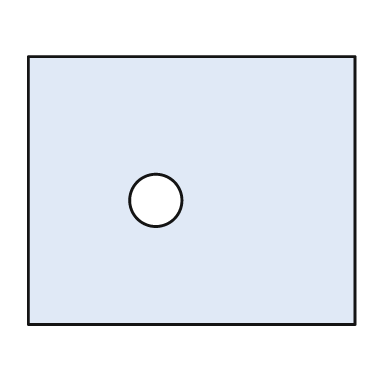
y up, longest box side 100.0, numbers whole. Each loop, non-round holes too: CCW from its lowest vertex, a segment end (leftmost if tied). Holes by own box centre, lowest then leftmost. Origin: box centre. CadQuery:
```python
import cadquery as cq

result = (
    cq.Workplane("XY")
    .moveTo(-50.0, -41.0)
    .lineTo(50.0, -41.0)
    .lineTo(50.0, 41.0)
    .lineTo(-50.0, 41.0)
    .close()
    .moveTo(-11.0, -3.0)
    .circle(8.0)
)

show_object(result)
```